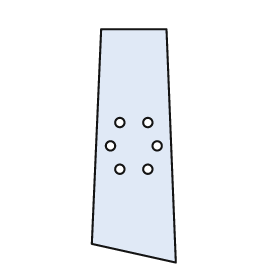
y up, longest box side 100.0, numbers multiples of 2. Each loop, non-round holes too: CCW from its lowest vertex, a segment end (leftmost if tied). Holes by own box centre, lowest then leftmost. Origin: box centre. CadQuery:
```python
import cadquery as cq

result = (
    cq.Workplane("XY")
    .moveTo(18.0, -50.0)
    .lineTo(14.0, 50.0)
    .lineTo(-14.0, 50.0)
    .lineTo(-18.0, -42.0)
    .close()
    .moveTo(-6.0, -10.0)
    .circle(2.0)
    .moveTo(6.0, -10.0)
    .circle(2.0)
    .moveTo(-10.0, 0.0)
    .circle(2.0)
    .moveTo(10.0, 0.0)
    .circle(2.0)
    .moveTo(-6.0, 10.0)
    .circle(2.0)
    .moveTo(6.0, 10.0)
    .circle(2.0)
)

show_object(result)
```